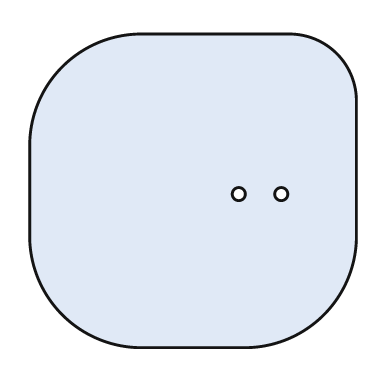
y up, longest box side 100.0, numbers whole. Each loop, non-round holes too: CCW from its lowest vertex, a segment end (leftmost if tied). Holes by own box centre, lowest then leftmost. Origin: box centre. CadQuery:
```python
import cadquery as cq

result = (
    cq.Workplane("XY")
    .moveTo(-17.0, -48.0)
    .lineTo(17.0, -48.0)
    .threePointArc((40.0, -38.0), (50.0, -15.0))
    .lineTo(50.0, 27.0)
    .threePointArc((44.0, 42.0), (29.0, 48.0))
    .lineTo(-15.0, 48.0)
    .threePointArc((-40.0, 38.0), (-50.0, 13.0))
    .lineTo(-50.0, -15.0)
    .threePointArc((-40.0, -38.0), (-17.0, -48.0))
    .close()
    .moveTo(14.0, -1.0)
    .circle(2.0)
    .moveTo(27.0, -1.0)
    .circle(2.0)
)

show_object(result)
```